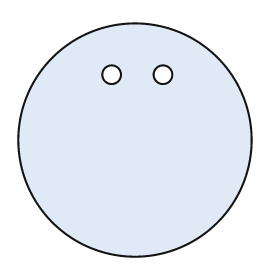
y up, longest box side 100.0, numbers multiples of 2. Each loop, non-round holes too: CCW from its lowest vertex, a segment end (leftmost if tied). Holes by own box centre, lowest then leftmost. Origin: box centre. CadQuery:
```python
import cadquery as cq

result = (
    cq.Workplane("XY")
    .moveTo(0.0, 0.0)
    .circle(50.0)
    .moveTo(-10.0, 28.0)
    .circle(4.0)
    .moveTo(12.0, 28.0)
    .circle(4.0)
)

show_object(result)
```